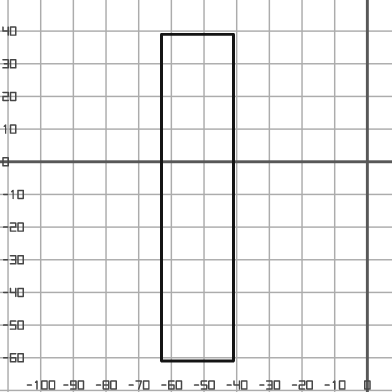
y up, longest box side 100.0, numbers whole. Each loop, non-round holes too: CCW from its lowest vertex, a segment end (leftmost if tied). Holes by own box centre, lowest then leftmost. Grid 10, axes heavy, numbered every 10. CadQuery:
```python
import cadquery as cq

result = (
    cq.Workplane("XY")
    .moveTo(-63.0, -61.0)
    .lineTo(-41.0, -61.0)
    .lineTo(-41.0, 39.0)
    .lineTo(-63.0, 39.0)
    .close()
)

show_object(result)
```